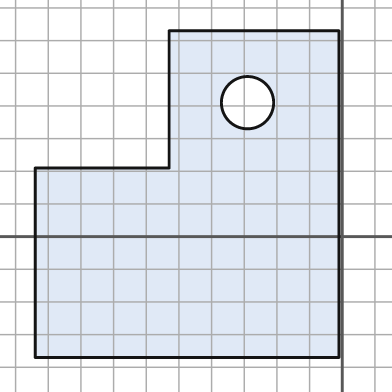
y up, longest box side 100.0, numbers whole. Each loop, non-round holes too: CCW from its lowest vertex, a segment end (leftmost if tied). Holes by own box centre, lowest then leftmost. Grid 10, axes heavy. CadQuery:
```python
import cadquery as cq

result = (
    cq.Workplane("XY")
    .moveTo(-94.0, -37.0)
    .lineTo(-1.0, -37.0)
    .lineTo(-1.0, 63.0)
    .lineTo(-53.0, 63.0)
    .lineTo(-53.0, 21.0)
    .lineTo(-94.0, 21.0)
    .close()
    .moveTo(-29.0, 41.0)
    .circle(8.0)
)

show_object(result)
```